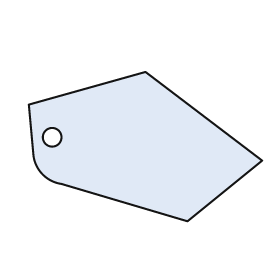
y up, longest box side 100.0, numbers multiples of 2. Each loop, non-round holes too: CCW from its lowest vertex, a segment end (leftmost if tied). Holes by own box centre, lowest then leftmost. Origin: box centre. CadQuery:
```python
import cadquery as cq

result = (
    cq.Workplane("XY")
    .moveTo(18.0, -32.0)
    .lineTo(50.0, -6.0)
    .lineTo(0.0, 32.0)
    .lineTo(-50.0, 18.0)
    .lineTo(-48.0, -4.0)
    .threePointArc((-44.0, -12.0), (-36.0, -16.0))
    .close()
    .moveTo(-40.0, 4.0)
    .circle(4.0)
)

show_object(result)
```